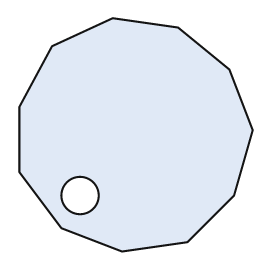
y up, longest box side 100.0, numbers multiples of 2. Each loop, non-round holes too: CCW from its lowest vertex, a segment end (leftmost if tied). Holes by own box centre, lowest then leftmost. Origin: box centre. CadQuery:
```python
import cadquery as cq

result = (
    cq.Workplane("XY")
    .moveTo(-6.0, -50.0)
    .lineTo(22.0, -46.0)
    .lineTo(42.0, -26.0)
    .lineTo(50.0, 2.0)
    .lineTo(40.0, 28.0)
    .lineTo(18.0, 46.0)
    .lineTo(-10.0, 50.0)
    .lineTo(-36.0, 38.0)
    .lineTo(-50.0, 12.0)
    .lineTo(-50.0, -16.0)
    .lineTo(-32.0, -40.0)
    .close()
    .moveTo(-24.0, -26.0)
    .circle(8.0)
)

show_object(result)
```